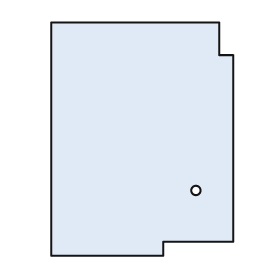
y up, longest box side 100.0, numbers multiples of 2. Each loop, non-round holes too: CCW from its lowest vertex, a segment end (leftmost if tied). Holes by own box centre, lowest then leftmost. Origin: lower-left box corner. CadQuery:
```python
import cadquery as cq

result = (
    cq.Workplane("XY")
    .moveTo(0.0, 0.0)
    .lineTo(48.0, 0.0)
    .lineTo(48.0, 6.0)
    .lineTo(78.0, 6.0)
    .lineTo(78.0, 86.0)
    .lineTo(72.0, 86.0)
    .lineTo(72.0, 100.0)
    .lineTo(0.0, 100.0)
    .close()
    .moveTo(62.0, 28.0)
    .circle(2.0)
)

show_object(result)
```